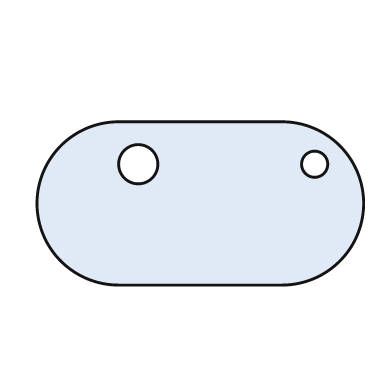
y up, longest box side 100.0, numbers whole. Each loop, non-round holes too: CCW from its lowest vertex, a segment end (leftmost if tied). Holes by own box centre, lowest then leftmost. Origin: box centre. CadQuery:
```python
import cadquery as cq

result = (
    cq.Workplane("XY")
    .moveTo(-25.0, -25.0)
    .lineTo(25.0, -25.0)
    .threePointArc((50.0, 0.0), (25.0, 25.0))
    .lineTo(-25.0, 25.0)
    .threePointArc((-50.0, 0.0), (-25.0, -25.0))
    .close()
    .moveTo(-19.0, 12.0)
    .circle(6.0)
    .moveTo(35.0, 12.0)
    .circle(4.0)
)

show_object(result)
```